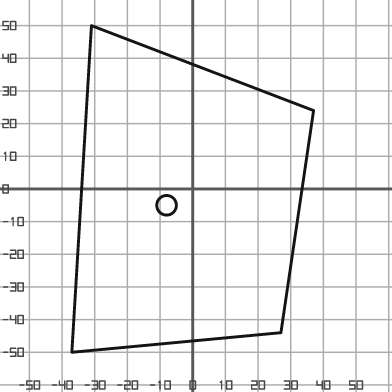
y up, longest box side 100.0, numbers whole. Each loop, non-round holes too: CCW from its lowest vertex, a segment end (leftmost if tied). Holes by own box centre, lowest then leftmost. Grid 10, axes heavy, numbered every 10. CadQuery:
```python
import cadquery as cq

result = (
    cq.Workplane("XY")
    .moveTo(-37.0, -50.0)
    .lineTo(27.0, -44.0)
    .lineTo(37.0, 24.0)
    .lineTo(-31.0, 50.0)
    .close()
    .moveTo(-8.0, -5.0)
    .circle(3.0)
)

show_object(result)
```